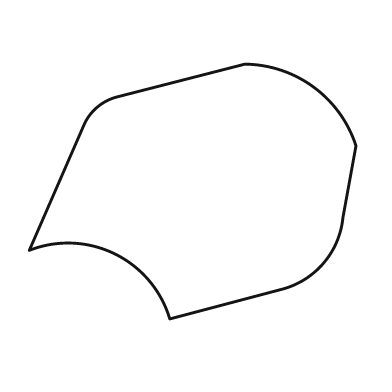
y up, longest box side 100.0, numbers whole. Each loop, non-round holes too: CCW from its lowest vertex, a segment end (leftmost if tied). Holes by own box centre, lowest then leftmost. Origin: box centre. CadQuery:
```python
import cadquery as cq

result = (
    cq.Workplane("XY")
    .moveTo(-7.0, -39.0)
    .lineTo(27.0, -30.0)
    .threePointArc((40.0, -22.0), (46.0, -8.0))
    .lineTo(50.0, 14.0)
    .threePointArc((37.0, 32.0), (16.0, 39.0))
    .lineTo(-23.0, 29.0)
    .threePointArc((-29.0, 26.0), (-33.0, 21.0))
    .lineTo(-50.0, -18.0)
    .threePointArc((-24.0, -19.0), (-7.0, -39.0))
    .close()
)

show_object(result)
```